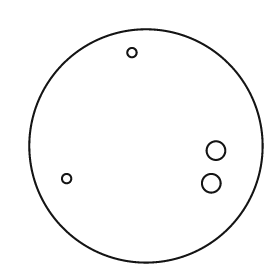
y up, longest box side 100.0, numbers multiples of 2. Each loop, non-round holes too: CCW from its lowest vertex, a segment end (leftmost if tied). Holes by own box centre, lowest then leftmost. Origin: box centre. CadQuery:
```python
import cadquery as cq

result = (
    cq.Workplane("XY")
    .moveTo(0.0, 0.0)
    .circle(50.0)
    .moveTo(28.0, -16.0)
    .circle(4.0)
    .moveTo(-34.0, -14.0)
    .circle(2.0)
    .moveTo(30.0, -2.0)
    .circle(4.0)
    .moveTo(-6.0, 40.0)
    .circle(2.0)
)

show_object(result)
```